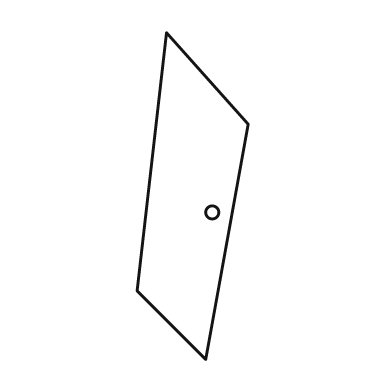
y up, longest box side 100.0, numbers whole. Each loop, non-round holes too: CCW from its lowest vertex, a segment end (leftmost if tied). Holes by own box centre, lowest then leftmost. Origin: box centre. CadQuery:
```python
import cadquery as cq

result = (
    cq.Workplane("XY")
    .moveTo(4.0, -50.0)
    .lineTo(17.0, 22.0)
    .lineTo(-8.0, 50.0)
    .lineTo(-17.0, -29.0)
    .close()
    .moveTo(6.0, -5.0)
    .circle(2.0)
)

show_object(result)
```